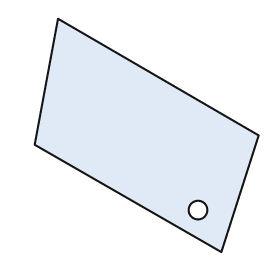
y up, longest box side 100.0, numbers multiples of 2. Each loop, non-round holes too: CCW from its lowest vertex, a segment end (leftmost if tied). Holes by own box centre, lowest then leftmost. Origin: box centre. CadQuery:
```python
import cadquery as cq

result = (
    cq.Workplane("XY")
    .moveTo(32.0, -50.0)
    .lineTo(48.0, 0.0)
    .lineTo(-38.0, 50.0)
    .lineTo(-48.0, -4.0)
    .close()
    .moveTo(22.0, -32.0)
    .circle(4.0)
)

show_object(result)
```